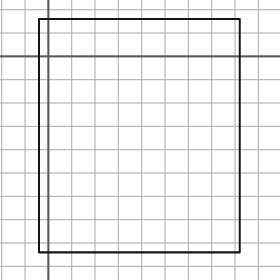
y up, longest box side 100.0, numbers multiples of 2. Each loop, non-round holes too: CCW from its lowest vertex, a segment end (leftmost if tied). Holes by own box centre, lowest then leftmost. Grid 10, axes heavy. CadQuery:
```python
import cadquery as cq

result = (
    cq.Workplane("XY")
    .moveTo(-4.0, -84.0)
    .lineTo(82.0, -84.0)
    .lineTo(82.0, 16.0)
    .lineTo(-4.0, 16.0)
    .close()
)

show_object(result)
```